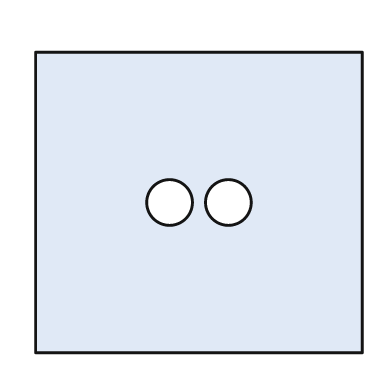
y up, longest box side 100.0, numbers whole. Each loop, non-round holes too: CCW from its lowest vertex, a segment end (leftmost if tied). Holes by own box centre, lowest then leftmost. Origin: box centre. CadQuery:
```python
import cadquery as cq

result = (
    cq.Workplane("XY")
    .moveTo(-50.0, -46.0)
    .lineTo(50.0, -46.0)
    .lineTo(50.0, 46.0)
    .lineTo(-50.0, 46.0)
    .close()
    .moveTo(-9.0, 0.0)
    .circle(7.0)
    .moveTo(9.0, 0.0)
    .circle(7.0)
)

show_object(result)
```